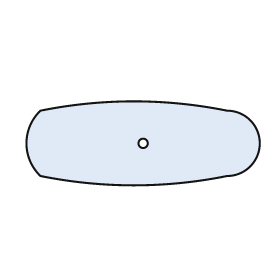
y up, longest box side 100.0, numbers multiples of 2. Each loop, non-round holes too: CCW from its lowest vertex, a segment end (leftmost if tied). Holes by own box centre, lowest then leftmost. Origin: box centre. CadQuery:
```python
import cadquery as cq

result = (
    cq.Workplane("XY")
    .moveTo(-44.0, -14.0)
    .threePointArc((-4.0, -18.0), (36.0, -14.0))
    .threePointArc((50.0, 0.0), (36.0, 14.0))
    .threePointArc((-4.0, 18.0), (-44.0, 14.0))
    .threePointArc((-50.0, 0.0), (-44.0, -14.0))
    .close()
    .moveTo(0.0, 0.0)
    .circle(2.0)
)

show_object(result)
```